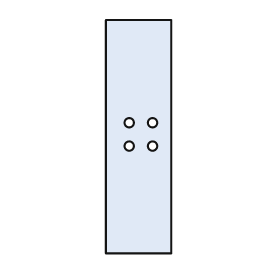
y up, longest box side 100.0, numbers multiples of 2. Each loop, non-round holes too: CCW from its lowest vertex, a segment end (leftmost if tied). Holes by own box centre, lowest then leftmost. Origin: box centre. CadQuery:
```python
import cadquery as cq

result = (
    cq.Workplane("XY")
    .moveTo(-14.0, -50.0)
    .lineTo(14.0, -50.0)
    .lineTo(14.0, 50.0)
    .lineTo(-14.0, 50.0)
    .close()
    .moveTo(-4.0, -4.0)
    .circle(2.0)
    .moveTo(6.0, -4.0)
    .circle(2.0)
    .moveTo(-4.0, 6.0)
    .circle(2.0)
    .moveTo(6.0, 6.0)
    .circle(2.0)
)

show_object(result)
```